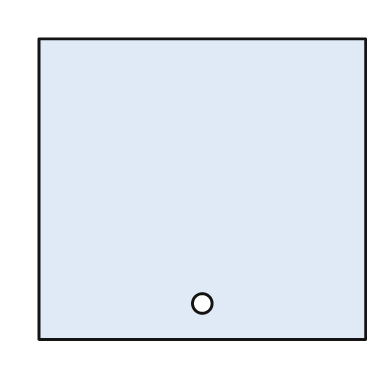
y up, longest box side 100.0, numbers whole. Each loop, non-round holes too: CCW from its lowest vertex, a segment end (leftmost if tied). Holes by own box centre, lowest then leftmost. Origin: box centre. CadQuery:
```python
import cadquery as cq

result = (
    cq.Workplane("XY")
    .moveTo(-50.0, -46.0)
    .lineTo(50.0, -46.0)
    .lineTo(50.0, 46.0)
    .lineTo(-50.0, 46.0)
    .close()
    .moveTo(0.0, -35.0)
    .circle(3.0)
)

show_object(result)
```